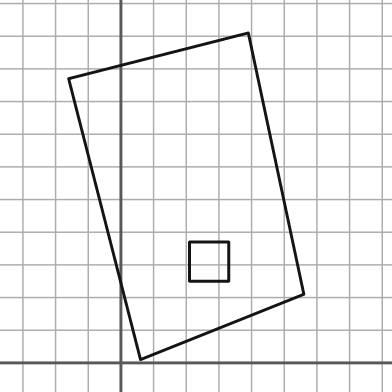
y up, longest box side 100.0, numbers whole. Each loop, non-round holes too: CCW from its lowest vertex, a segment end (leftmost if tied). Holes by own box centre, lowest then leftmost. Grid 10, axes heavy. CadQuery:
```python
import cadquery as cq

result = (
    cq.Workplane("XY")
    .moveTo(6.0, 1.0)
    .lineTo(56.0, 21.0)
    .lineTo(39.0, 101.0)
    .lineTo(-16.0, 87.0)
    .close()
    .moveTo(21.0, 25.0)
    .lineTo(33.0, 25.0)
    .lineTo(33.0, 37.0)
    .lineTo(21.0, 37.0)
    .close()
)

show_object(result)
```